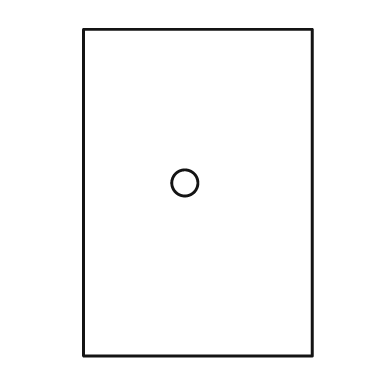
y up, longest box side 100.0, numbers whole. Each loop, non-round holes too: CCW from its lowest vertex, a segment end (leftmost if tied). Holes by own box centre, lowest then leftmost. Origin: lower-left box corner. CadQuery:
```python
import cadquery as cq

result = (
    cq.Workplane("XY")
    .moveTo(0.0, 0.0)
    .lineTo(70.0, 0.0)
    .lineTo(70.0, 100.0)
    .lineTo(0.0, 100.0)
    .close()
    .moveTo(31.0, 53.0)
    .circle(4.0)
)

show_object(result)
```